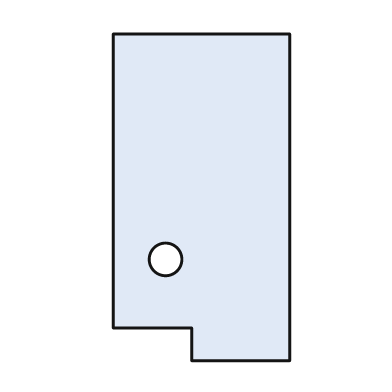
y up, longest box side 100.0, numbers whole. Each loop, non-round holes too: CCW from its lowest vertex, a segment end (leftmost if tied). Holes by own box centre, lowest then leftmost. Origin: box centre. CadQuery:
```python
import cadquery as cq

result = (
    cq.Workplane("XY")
    .moveTo(-3.0, -50.0)
    .lineTo(27.0, -50.0)
    .lineTo(27.0, 50.0)
    .lineTo(-27.0, 50.0)
    .lineTo(-27.0, -40.0)
    .lineTo(-3.0, -40.0)
    .close()
    .moveTo(-11.0, -19.0)
    .circle(5.0)
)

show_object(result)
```